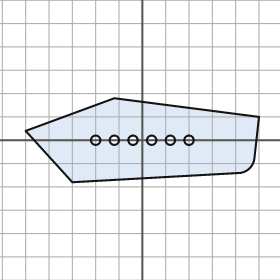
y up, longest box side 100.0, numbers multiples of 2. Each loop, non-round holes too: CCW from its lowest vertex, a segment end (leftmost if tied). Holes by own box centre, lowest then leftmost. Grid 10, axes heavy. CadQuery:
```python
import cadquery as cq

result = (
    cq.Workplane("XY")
    .moveTo(-30.0, -18.0)
    .lineTo(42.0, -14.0)
    .threePointArc((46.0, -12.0), (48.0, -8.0))
    .lineTo(50.0, 10.0)
    .lineTo(-12.0, 18.0)
    .lineTo(-50.0, 4.0)
    .close()
    .moveTo(-20.0, 0.0)
    .circle(2.0)
    .moveTo(-12.0, 0.0)
    .circle(2.0)
    .moveTo(-4.0, 0.0)
    .circle(2.0)
    .moveTo(4.0, 0.0)
    .circle(2.0)
    .moveTo(12.0, 0.0)
    .circle(2.0)
    .moveTo(20.0, 0.0)
    .circle(2.0)
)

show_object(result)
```